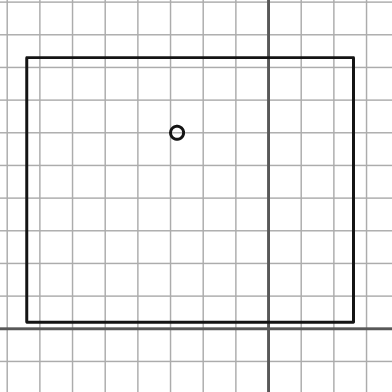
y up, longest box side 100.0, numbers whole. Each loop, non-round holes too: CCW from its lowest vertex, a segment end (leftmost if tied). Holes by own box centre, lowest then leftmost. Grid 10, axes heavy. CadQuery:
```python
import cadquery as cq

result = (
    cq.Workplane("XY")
    .moveTo(-74.0, 2.0)
    .lineTo(26.0, 2.0)
    .lineTo(26.0, 83.0)
    .lineTo(-74.0, 83.0)
    .close()
    .moveTo(-28.0, 60.0)
    .circle(2.0)
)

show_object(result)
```